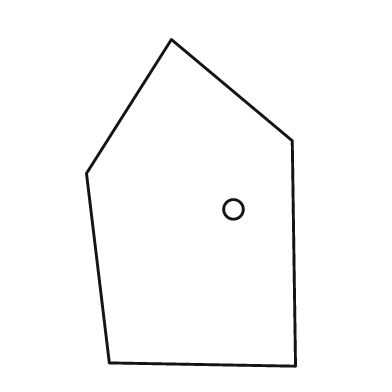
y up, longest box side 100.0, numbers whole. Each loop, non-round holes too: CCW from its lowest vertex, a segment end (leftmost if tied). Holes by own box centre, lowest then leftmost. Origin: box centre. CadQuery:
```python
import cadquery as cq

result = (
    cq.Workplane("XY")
    .moveTo(32.0, -50.0)
    .lineTo(31.0, 19.0)
    .lineTo(-6.0, 50.0)
    .lineTo(-32.0, 9.0)
    .lineTo(-25.0, -49.0)
    .close()
    .moveTo(13.0, -2.0)
    .circle(3.0)
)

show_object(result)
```